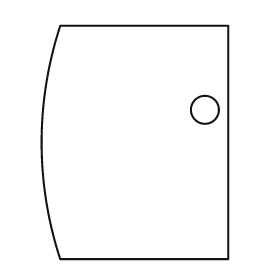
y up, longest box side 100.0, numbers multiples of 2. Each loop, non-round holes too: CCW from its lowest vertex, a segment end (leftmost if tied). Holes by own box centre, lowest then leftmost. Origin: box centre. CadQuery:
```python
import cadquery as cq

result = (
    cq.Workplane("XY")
    .moveTo(-32.0, -50.0)
    .lineTo(40.0, -50.0)
    .lineTo(40.0, 50.0)
    .lineTo(-32.0, 50.0)
    .threePointArc((-40.0, 0.0), (-32.0, -50.0))
    .close()
    .moveTo(30.0, 14.0)
    .circle(6.0)
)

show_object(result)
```